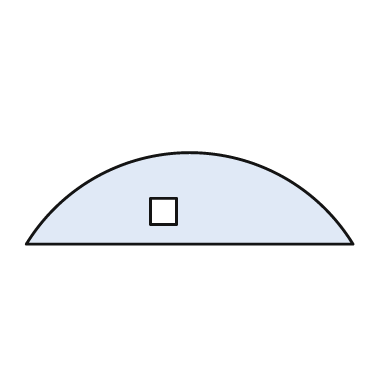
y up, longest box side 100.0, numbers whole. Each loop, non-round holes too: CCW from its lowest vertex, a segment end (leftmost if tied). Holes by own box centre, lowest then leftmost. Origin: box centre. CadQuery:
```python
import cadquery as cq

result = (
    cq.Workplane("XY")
    .moveTo(-50.0, -14.0)
    .lineTo(50.0, -14.0)
    .threePointArc((0.0, 14.0), (-50.0, -14.0))
    .close()
    .moveTo(-12.0, -8.0)
    .lineTo(-4.0, -8.0)
    .lineTo(-4.0, 0.0)
    .lineTo(-12.0, 0.0)
    .close()
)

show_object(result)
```